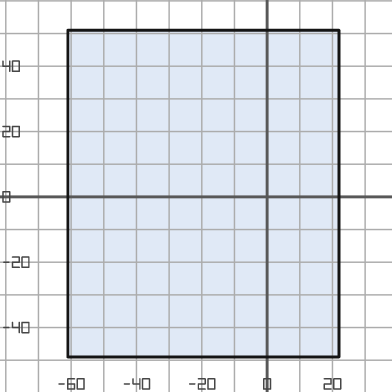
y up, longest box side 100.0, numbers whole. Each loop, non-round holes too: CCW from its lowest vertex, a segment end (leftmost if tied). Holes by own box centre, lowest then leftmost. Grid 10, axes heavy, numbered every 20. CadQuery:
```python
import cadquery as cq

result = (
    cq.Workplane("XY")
    .moveTo(-61.0, -49.0)
    .lineTo(22.0, -49.0)
    .lineTo(22.0, 51.0)
    .lineTo(-61.0, 51.0)
    .close()
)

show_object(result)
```